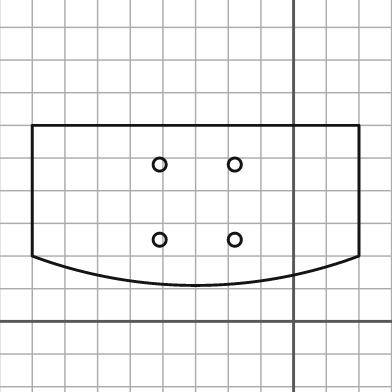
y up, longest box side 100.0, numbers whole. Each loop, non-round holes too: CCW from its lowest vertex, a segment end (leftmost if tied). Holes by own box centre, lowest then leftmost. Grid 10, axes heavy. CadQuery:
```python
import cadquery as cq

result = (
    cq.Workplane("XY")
    .moveTo(-80.0, 20.0)
    .threePointArc((-30.0, 11.0), (20.0, 20.0))
    .lineTo(20.0, 60.0)
    .lineTo(-80.0, 60.0)
    .close()
    .moveTo(-41.0, 25.0)
    .circle(2.0)
    .moveTo(-18.0, 25.0)
    .circle(2.0)
    .moveTo(-41.0, 48.0)
    .circle(2.0)
    .moveTo(-18.0, 48.0)
    .circle(2.0)
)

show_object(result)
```